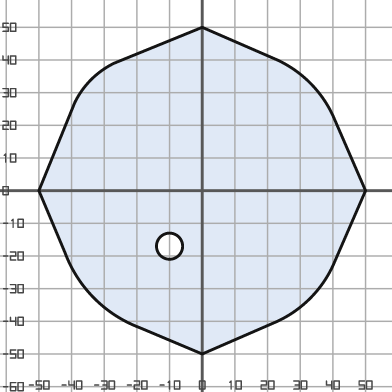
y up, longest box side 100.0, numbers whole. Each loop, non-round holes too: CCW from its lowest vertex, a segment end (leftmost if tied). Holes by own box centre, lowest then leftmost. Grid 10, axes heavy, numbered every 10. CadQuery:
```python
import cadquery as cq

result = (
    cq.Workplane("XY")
    .moveTo(0.0, -50.0)
    .lineTo(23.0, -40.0)
    .threePointArc((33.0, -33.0), (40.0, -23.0))
    .lineTo(50.0, 0.0)
    .lineTo(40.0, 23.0)
    .threePointArc((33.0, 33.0), (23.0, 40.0))
    .lineTo(0.0, 50.0)
    .lineTo(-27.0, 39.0)
    .threePointArc((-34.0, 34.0), (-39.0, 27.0))
    .lineTo(-50.0, 0.0)
    .lineTo(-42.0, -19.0)
    .threePointArc((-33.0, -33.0), (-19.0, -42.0))
    .close()
    .moveTo(-10.0, -17.0)
    .circle(4.0)
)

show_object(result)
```